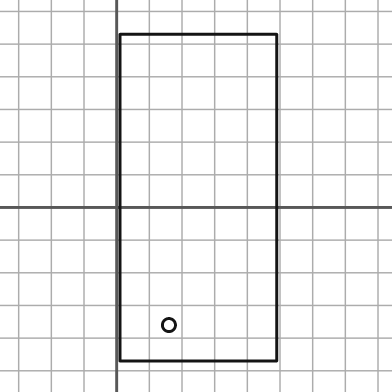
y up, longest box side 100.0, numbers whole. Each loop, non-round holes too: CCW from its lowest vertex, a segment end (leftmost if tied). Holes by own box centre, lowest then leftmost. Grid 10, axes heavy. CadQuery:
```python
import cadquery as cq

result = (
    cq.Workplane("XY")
    .moveTo(1.0, -47.0)
    .lineTo(49.0, -47.0)
    .lineTo(49.0, 53.0)
    .lineTo(1.0, 53.0)
    .close()
    .moveTo(16.0, -36.0)
    .circle(2.0)
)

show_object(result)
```